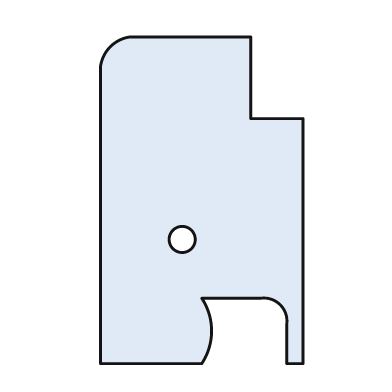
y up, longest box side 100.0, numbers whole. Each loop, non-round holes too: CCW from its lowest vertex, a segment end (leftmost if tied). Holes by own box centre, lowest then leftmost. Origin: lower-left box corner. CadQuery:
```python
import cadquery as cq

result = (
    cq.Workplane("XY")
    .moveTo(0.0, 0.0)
    .lineTo(31.0, 0.0)
    .threePointArc((34.0, 10.0), (31.0, 20.0))
    .lineTo(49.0, 20.0)
    .threePointArc((55.0, 18.0), (57.0, 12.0))
    .lineTo(57.0, 0.0)
    .lineTo(62.0, 0.0)
    .lineTo(62.0, 75.0)
    .lineTo(46.0, 75.0)
    .lineTo(46.0, 100.0)
    .lineTo(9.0, 100.0)
    .threePointArc((3.0, 97.0), (0.0, 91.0))
    .close()
    .moveTo(25.0, 38.0)
    .circle(4.0)
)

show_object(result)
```